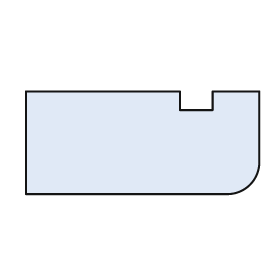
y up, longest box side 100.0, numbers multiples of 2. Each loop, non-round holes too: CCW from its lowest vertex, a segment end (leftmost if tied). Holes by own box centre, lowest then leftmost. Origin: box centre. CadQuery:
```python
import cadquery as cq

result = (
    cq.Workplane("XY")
    .moveTo(-50.0, -22.0)
    .lineTo(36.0, -22.0)
    .threePointArc((46.0, -18.0), (50.0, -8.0))
    .lineTo(50.0, 22.0)
    .lineTo(30.0, 22.0)
    .lineTo(30.0, 14.0)
    .lineTo(16.0, 14.0)
    .lineTo(16.0, 22.0)
    .lineTo(-50.0, 22.0)
    .close()
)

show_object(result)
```